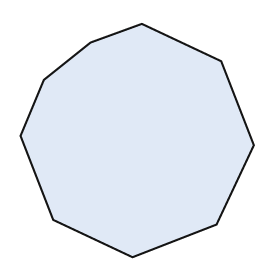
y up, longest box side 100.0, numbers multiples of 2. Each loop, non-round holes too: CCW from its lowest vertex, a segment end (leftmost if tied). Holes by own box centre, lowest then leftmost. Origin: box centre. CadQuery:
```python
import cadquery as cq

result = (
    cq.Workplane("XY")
    .moveTo(-2.0, -50.0)
    .lineTo(34.0, -36.0)
    .lineTo(50.0, -2.0)
    .lineTo(36.0, 34.0)
    .lineTo(2.0, 50.0)
    .lineTo(-20.0, 42.0)
    .lineTo(-40.0, 26.0)
    .lineTo(-50.0, 2.0)
    .lineTo(-36.0, -34.0)
    .close()
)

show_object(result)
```